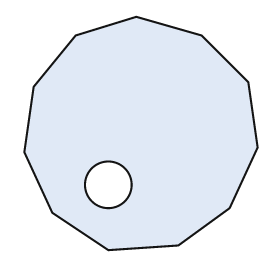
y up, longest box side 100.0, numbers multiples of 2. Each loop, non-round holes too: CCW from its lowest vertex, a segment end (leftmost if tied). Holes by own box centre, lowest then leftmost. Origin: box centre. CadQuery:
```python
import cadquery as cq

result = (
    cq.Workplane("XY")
    .moveTo(-14.0, -50.0)
    .lineTo(16.0, -48.0)
    .lineTo(38.0, -32.0)
    .lineTo(50.0, -6.0)
    .lineTo(46.0, 22.0)
    .lineTo(26.0, 42.0)
    .lineTo(-2.0, 50.0)
    .lineTo(-28.0, 42.0)
    .lineTo(-46.0, 20.0)
    .lineTo(-50.0, -8.0)
    .lineTo(-38.0, -34.0)
    .close()
    .moveTo(-14.0, -22.0)
    .circle(10.0)
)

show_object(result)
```